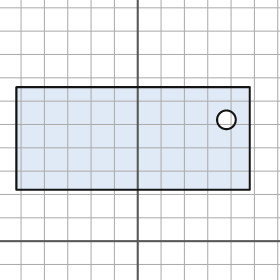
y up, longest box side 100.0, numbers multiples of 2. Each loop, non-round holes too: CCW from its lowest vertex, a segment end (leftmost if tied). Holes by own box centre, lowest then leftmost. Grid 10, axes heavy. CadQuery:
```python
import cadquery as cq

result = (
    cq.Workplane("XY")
    .moveTo(-52.0, 22.0)
    .lineTo(48.0, 22.0)
    .lineTo(48.0, 66.0)
    .lineTo(-52.0, 66.0)
    .close()
    .moveTo(38.0, 52.0)
    .circle(4.0)
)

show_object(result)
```